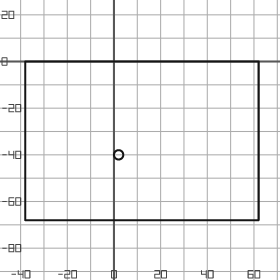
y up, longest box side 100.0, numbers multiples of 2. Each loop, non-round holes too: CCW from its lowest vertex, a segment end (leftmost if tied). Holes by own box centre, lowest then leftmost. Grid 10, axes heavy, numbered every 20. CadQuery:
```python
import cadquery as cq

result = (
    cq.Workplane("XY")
    .moveTo(-38.0, -68.0)
    .lineTo(62.0, -68.0)
    .lineTo(62.0, 0.0)
    .lineTo(-38.0, 0.0)
    .close()
    .moveTo(2.0, -40.0)
    .circle(2.0)
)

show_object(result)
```